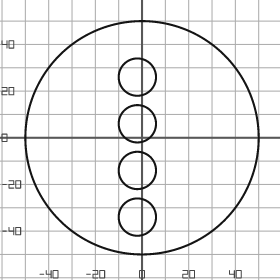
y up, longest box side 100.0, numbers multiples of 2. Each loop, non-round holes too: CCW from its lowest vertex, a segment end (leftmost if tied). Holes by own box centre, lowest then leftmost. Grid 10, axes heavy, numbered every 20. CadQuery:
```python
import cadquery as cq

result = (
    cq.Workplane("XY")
    .moveTo(0.0, 0.0)
    .circle(50.0)
    .moveTo(-2.0, -34.0)
    .circle(8.0)
    .moveTo(-2.0, -14.0)
    .circle(8.0)
    .moveTo(-2.0, 6.0)
    .circle(8.0)
    .moveTo(-2.0, 26.0)
    .circle(8.0)
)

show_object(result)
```